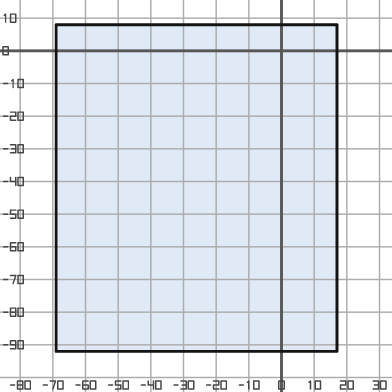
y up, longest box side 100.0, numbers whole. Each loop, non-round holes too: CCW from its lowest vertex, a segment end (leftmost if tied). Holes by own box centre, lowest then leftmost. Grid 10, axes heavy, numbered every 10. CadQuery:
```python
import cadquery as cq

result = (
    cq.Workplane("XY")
    .moveTo(-69.0, -92.0)
    .lineTo(17.0, -92.0)
    .lineTo(17.0, 8.0)
    .lineTo(-69.0, 8.0)
    .close()
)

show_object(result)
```